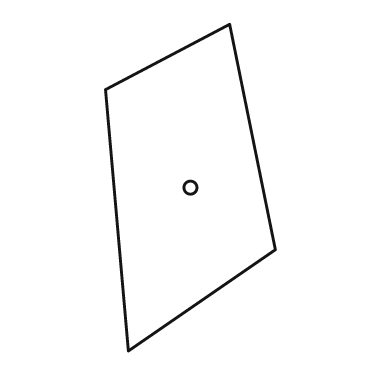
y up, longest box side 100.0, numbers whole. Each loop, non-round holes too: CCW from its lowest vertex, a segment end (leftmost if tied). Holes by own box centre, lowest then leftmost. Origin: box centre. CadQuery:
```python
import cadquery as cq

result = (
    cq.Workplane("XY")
    .moveTo(-19.0, -50.0)
    .lineTo(26.0, -19.0)
    .lineTo(12.0, 50.0)
    .lineTo(-26.0, 30.0)
    .close()
    .moveTo(0.0, 0.0)
    .circle(2.0)
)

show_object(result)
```